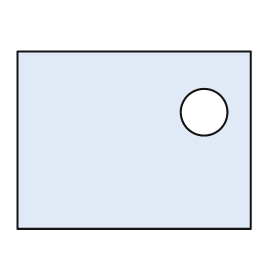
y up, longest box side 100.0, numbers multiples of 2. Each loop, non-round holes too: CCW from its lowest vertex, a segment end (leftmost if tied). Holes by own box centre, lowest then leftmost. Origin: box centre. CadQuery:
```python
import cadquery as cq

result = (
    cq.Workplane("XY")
    .moveTo(-50.0, -38.0)
    .lineTo(50.0, -38.0)
    .lineTo(50.0, 38.0)
    .lineTo(-50.0, 38.0)
    .close()
    .moveTo(30.0, 12.0)
    .circle(10.0)
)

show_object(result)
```